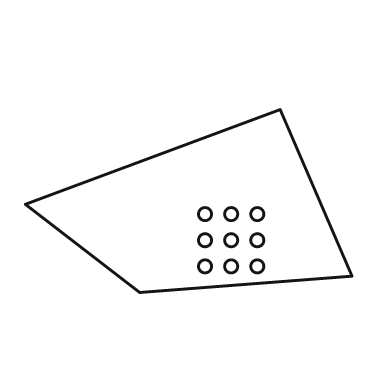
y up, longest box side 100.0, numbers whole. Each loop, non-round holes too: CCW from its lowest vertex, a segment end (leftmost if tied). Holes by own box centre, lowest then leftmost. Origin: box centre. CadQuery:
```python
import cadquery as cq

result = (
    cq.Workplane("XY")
    .moveTo(-15.0, -28.0)
    .lineTo(50.0, -23.0)
    .lineTo(28.0, 28.0)
    .lineTo(-50.0, -1.0)
    .close()
    .moveTo(5.0, -20.0)
    .circle(2.0)
    .moveTo(13.0, -20.0)
    .circle(2.0)
    .moveTo(21.0, -20.0)
    .circle(2.0)
    .moveTo(5.0, -12.0)
    .circle(2.0)
    .moveTo(13.0, -12.0)
    .circle(2.0)
    .moveTo(21.0, -12.0)
    .circle(2.0)
    .moveTo(5.0, -4.0)
    .circle(2.0)
    .moveTo(13.0, -4.0)
    .circle(2.0)
    .moveTo(21.0, -4.0)
    .circle(2.0)
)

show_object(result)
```